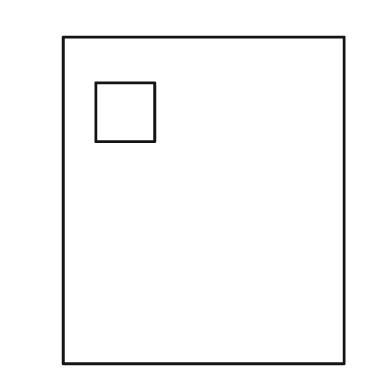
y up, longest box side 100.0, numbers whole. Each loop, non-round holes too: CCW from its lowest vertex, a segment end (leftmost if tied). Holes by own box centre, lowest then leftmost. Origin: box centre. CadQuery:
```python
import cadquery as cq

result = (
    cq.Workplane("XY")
    .moveTo(-43.0, -50.0)
    .lineTo(43.0, -50.0)
    .lineTo(43.0, 50.0)
    .lineTo(-43.0, 50.0)
    .close()
    .moveTo(-33.0, 18.0)
    .lineTo(-15.0, 18.0)
    .lineTo(-15.0, 36.0)
    .lineTo(-33.0, 36.0)
    .close()
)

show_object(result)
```